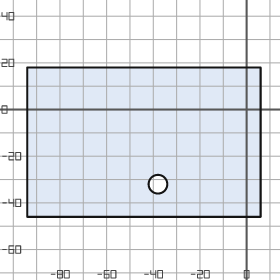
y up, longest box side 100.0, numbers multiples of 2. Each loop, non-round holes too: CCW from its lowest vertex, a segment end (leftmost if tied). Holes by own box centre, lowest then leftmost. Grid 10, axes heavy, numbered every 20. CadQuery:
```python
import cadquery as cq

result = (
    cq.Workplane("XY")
    .moveTo(-94.0, -46.0)
    .lineTo(6.0, -46.0)
    .lineTo(6.0, 18.0)
    .lineTo(-94.0, 18.0)
    .close()
    .moveTo(-38.0, -32.0)
    .circle(4.0)
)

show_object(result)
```